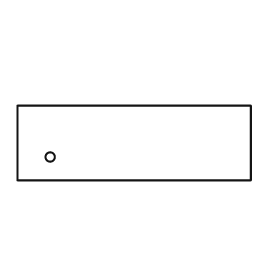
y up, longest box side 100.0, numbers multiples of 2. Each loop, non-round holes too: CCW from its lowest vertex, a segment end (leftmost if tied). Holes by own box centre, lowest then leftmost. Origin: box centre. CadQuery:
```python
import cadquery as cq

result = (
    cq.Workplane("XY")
    .moveTo(-50.0, -16.0)
    .lineTo(50.0, -16.0)
    .lineTo(50.0, 16.0)
    .lineTo(-50.0, 16.0)
    .close()
    .moveTo(-36.0, -6.0)
    .circle(2.0)
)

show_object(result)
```